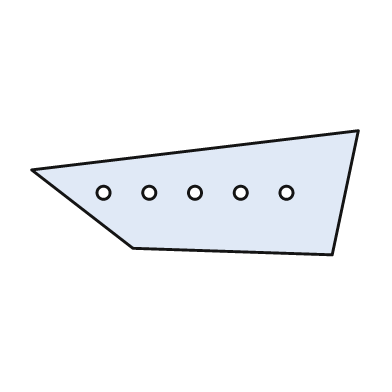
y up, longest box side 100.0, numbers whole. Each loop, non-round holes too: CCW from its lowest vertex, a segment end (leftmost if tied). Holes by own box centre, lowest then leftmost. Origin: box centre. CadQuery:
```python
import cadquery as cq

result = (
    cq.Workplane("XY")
    .moveTo(42.0, -19.0)
    .lineTo(50.0, 19.0)
    .lineTo(-50.0, 7.0)
    .lineTo(-19.0, -17.0)
    .close()
    .moveTo(-28.0, 0.0)
    .circle(2.0)
    .moveTo(-14.0, 0.0)
    .circle(2.0)
    .moveTo(0.0, 0.0)
    .circle(2.0)
    .moveTo(14.0, 0.0)
    .circle(2.0)
    .moveTo(28.0, 0.0)
    .circle(2.0)
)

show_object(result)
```